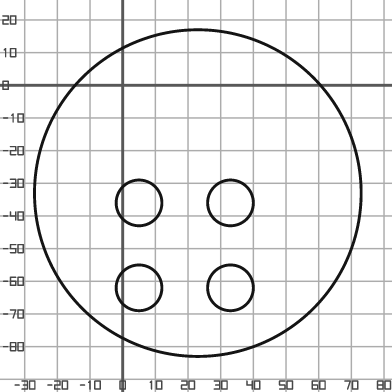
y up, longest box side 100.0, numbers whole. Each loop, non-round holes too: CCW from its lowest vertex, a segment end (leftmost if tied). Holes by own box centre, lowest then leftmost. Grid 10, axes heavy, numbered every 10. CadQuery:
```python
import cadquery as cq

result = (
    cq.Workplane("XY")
    .moveTo(23.0, -33.0)
    .circle(50.0)
    .moveTo(5.0, -62.0)
    .circle(7.0)
    .moveTo(33.0, -62.0)
    .circle(7.0)
    .moveTo(5.0, -36.0)
    .circle(7.0)
    .moveTo(33.0, -36.0)
    .circle(7.0)
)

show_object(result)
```